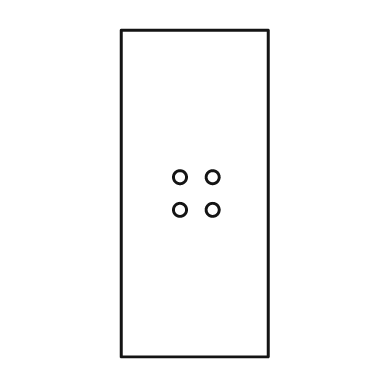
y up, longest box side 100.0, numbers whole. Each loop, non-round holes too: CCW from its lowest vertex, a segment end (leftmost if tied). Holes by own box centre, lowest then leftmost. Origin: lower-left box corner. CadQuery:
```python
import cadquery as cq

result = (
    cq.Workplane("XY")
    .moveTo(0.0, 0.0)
    .lineTo(45.0, 0.0)
    .lineTo(45.0, 100.0)
    .lineTo(0.0, 100.0)
    .close()
    .moveTo(18.0, 45.0)
    .circle(2.0)
    .moveTo(28.0, 45.0)
    .circle(2.0)
    .moveTo(18.0, 55.0)
    .circle(2.0)
    .moveTo(28.0, 55.0)
    .circle(2.0)
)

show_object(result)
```